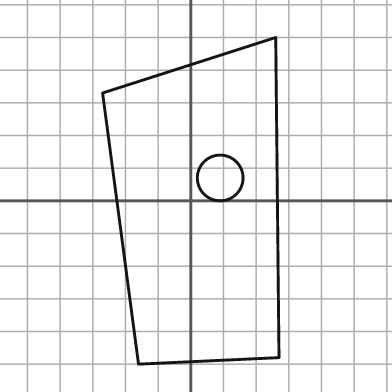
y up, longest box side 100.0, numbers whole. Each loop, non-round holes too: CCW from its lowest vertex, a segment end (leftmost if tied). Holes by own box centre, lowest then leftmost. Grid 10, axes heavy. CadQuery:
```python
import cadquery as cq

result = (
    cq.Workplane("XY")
    .moveTo(-16.0, -50.0)
    .lineTo(27.0, -48.0)
    .lineTo(26.0, 50.0)
    .lineTo(-27.0, 33.0)
    .close()
    .moveTo(9.0, 7.0)
    .circle(7.0)
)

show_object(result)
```